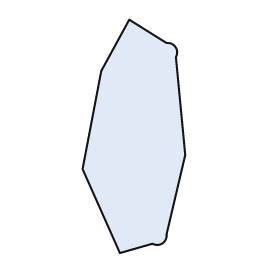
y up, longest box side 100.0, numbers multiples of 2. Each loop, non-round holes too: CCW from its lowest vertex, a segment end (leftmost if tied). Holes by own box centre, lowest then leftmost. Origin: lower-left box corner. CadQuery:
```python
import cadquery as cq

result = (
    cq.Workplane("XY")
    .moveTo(16.0, 0.0)
    .lineTo(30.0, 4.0)
    .threePointArc((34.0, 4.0), (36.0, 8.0))
    .lineTo(44.0, 42.0)
    .lineTo(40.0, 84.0)
    .threePointArc((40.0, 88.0), (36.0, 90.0))
    .lineTo(20.0, 100.0)
    .lineTo(8.0, 78.0)
    .lineTo(0.0, 36.0)
    .close()
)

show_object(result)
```